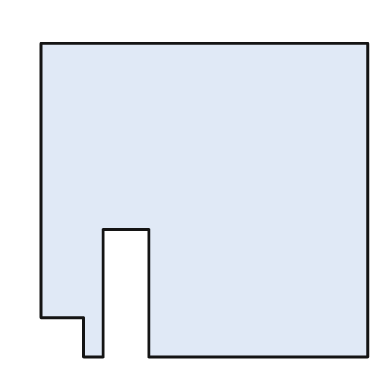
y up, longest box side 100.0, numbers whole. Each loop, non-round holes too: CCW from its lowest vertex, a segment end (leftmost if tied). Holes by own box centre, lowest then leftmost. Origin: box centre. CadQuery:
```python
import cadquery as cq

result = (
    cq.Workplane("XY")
    .moveTo(-37.0, -48.0)
    .lineTo(-31.0, -48.0)
    .lineTo(-31.0, -9.0)
    .lineTo(-17.0, -9.0)
    .lineTo(-17.0, -48.0)
    .lineTo(50.0, -48.0)
    .lineTo(50.0, 48.0)
    .lineTo(-50.0, 48.0)
    .lineTo(-50.0, -36.0)
    .lineTo(-37.0, -36.0)
    .close()
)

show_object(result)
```